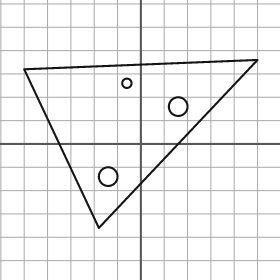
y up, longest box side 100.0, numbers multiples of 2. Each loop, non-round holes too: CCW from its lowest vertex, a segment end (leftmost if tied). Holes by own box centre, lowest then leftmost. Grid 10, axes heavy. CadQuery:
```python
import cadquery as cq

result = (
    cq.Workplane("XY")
    .moveTo(-18.0, -36.0)
    .lineTo(50.0, 36.0)
    .lineTo(-50.0, 32.0)
    .close()
    .moveTo(-14.0, -14.0)
    .circle(4.0)
    .moveTo(16.0, 16.0)
    .circle(4.0)
    .moveTo(-6.0, 26.0)
    .circle(2.0)
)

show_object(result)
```